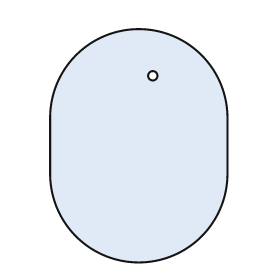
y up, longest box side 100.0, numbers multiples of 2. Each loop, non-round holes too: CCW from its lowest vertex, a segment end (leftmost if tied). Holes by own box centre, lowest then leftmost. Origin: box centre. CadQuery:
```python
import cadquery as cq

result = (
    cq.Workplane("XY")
    .moveTo(-38.0, -12.0)
    .threePointArc((0.0, -50.0), (38.0, -12.0))
    .lineTo(38.0, 12.0)
    .threePointArc((0.0, 50.0), (-38.0, 12.0))
    .close()
    .moveTo(6.0, 30.0)
    .circle(2.0)
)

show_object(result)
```